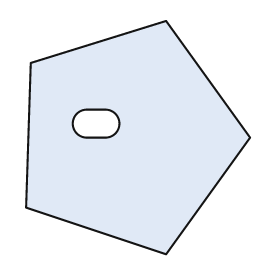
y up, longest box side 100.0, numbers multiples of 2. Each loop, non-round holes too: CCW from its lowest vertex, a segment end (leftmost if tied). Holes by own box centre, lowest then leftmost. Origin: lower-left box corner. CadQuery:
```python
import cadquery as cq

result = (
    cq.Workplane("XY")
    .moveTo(60.0, 0.0)
    .lineTo(96.0, 50.0)
    .lineTo(60.0, 100.0)
    .lineTo(2.0, 82.0)
    .lineTo(0.0, 20.0)
    .close()
    .moveTo(26.0, 50.0)
    .lineTo(34.0, 50.0)
    .threePointArc((40.0, 56.0), (34.0, 62.0))
    .lineTo(26.0, 62.0)
    .threePointArc((20.0, 56.0), (26.0, 50.0))
    .close()
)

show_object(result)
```